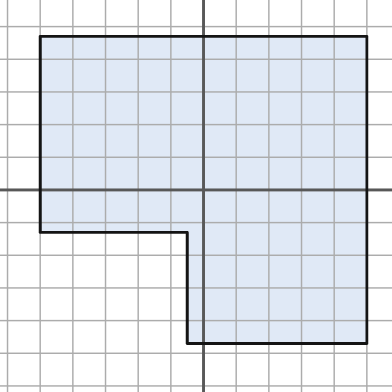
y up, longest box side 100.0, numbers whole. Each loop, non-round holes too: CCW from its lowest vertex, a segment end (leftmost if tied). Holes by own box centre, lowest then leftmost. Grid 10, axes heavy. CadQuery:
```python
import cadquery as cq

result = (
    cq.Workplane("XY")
    .moveTo(-5.0, -47.0)
    .lineTo(50.0, -47.0)
    .lineTo(50.0, 47.0)
    .lineTo(-50.0, 47.0)
    .lineTo(-50.0, -13.0)
    .lineTo(-5.0, -13.0)
    .close()
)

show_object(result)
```